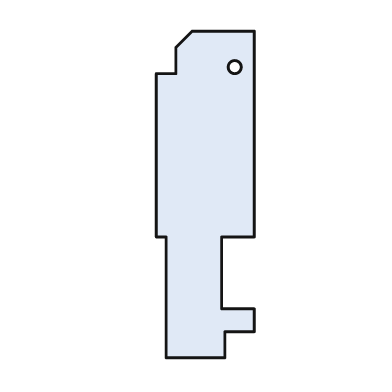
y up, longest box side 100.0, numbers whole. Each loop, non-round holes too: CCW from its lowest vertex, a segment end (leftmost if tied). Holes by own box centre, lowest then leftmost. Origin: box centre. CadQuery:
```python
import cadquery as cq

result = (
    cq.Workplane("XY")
    .moveTo(-12.0, -50.0)
    .lineTo(6.0, -50.0)
    .lineTo(6.0, -42.0)
    .lineTo(15.0, -42.0)
    .lineTo(15.0, -35.0)
    .lineTo(5.0, -35.0)
    .lineTo(5.0, -13.0)
    .lineTo(15.0, -13.0)
    .lineTo(15.0, 50.0)
    .lineTo(-4.0, 50.0)
    .lineTo(-9.0, 45.0)
    .lineTo(-9.0, 37.0)
    .lineTo(-15.0, 37.0)
    .lineTo(-15.0, -13.0)
    .lineTo(-12.0, -13.0)
    .close()
    .moveTo(9.0, 39.0)
    .circle(2.0)
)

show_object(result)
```